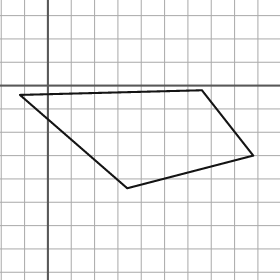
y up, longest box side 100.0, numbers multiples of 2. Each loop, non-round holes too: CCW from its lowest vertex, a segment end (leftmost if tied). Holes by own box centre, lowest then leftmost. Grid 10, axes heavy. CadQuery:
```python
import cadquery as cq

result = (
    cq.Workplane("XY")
    .moveTo(34.0, -44.0)
    .lineTo(88.0, -30.0)
    .lineTo(66.0, -2.0)
    .lineTo(-12.0, -4.0)
    .close()
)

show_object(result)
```